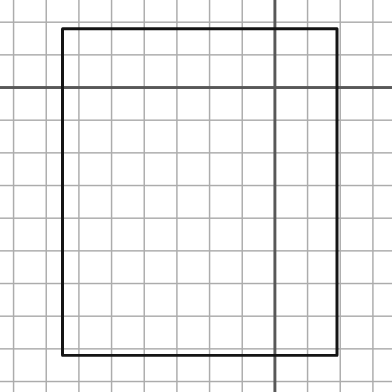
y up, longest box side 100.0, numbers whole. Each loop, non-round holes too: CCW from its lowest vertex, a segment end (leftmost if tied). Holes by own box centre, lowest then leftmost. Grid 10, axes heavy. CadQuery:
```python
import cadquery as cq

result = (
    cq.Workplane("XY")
    .moveTo(-65.0, -82.0)
    .lineTo(19.0, -82.0)
    .lineTo(19.0, 18.0)
    .lineTo(-65.0, 18.0)
    .close()
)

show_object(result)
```